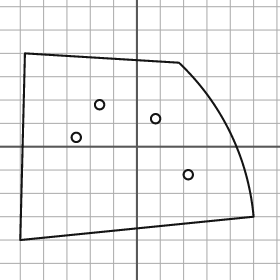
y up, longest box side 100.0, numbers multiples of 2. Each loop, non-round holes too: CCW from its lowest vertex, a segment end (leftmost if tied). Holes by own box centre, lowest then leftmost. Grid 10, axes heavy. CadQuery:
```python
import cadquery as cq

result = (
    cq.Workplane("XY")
    .moveTo(-50.0, -40.0)
    .lineTo(50.0, -30.0)
    .threePointArc((40.0, 6.0), (18.0, 36.0))
    .lineTo(-48.0, 40.0)
    .close()
    .moveTo(22.0, -12.0)
    .circle(2.0)
    .moveTo(-26.0, 4.0)
    .circle(2.0)
    .moveTo(8.0, 12.0)
    .circle(2.0)
    .moveTo(-16.0, 18.0)
    .circle(2.0)
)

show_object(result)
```